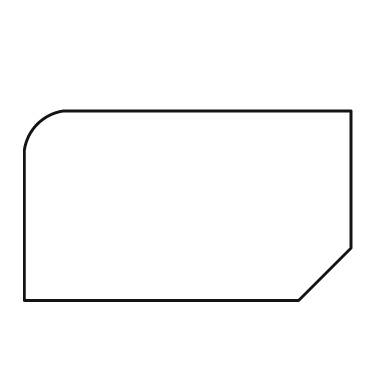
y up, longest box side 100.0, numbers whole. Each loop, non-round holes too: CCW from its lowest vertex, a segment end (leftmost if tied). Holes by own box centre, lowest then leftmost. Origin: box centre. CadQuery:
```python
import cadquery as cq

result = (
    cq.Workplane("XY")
    .moveTo(-50.0, -29.0)
    .lineTo(34.0, -29.0)
    .lineTo(50.0, -13.0)
    .lineTo(50.0, 29.0)
    .lineTo(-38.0, 29.0)
    .threePointArc((-46.0, 25.0), (-50.0, 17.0))
    .close()
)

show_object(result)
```